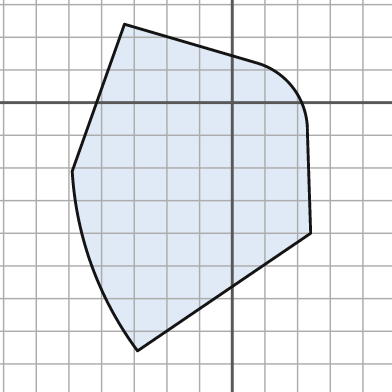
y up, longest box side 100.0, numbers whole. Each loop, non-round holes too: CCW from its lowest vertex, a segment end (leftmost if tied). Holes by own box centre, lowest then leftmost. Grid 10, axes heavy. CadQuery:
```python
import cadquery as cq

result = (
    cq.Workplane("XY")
    .moveTo(-29.0, -76.0)
    .lineTo(24.0, -40.0)
    .lineTo(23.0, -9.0)
    .threePointArc((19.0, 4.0), (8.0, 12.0))
    .lineTo(-33.0, 24.0)
    .lineTo(-49.0, -21.0)
    .threePointArc((-43.0, -50.0), (-29.0, -76.0))
    .close()
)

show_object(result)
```